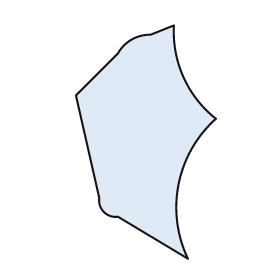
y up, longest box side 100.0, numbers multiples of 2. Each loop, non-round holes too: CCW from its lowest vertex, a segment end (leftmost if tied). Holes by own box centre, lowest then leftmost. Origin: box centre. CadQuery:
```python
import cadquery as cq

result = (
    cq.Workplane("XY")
    .moveTo(18.0, -50.0)
    .threePointArc((14.0, -18.0), (30.0, 10.0))
    .threePointArc((16.0, 28.0), (12.0, 50.0))
    .lineTo(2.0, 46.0)
    .threePointArc((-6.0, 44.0), (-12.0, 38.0))
    .lineTo(-30.0, 20.0)
    .lineTo(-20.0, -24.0)
    .threePointArc((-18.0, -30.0), (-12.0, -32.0))
    .close()
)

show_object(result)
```